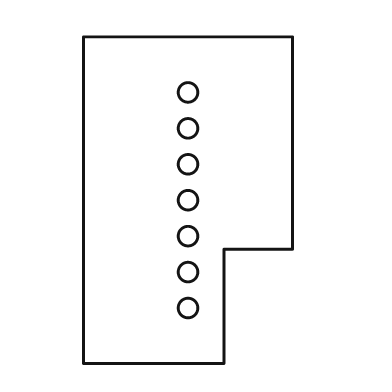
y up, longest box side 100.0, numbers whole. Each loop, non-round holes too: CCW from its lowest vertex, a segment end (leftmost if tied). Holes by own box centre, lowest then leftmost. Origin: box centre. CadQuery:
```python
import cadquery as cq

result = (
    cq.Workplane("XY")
    .moveTo(-32.0, -50.0)
    .lineTo(11.0, -50.0)
    .lineTo(11.0, -15.0)
    .lineTo(32.0, -15.0)
    .lineTo(32.0, 50.0)
    .lineTo(-32.0, 50.0)
    .close()
    .moveTo(0.0, -33.0)
    .circle(3.0)
    .moveTo(0.0, -22.0)
    .circle(3.0)
    .moveTo(0.0, -11.0)
    .circle(3.0)
    .moveTo(0.0, 0.0)
    .circle(3.0)
    .moveTo(0.0, 11.0)
    .circle(3.0)
    .moveTo(0.0, 22.0)
    .circle(3.0)
    .moveTo(0.0, 33.0)
    .circle(3.0)
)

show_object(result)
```